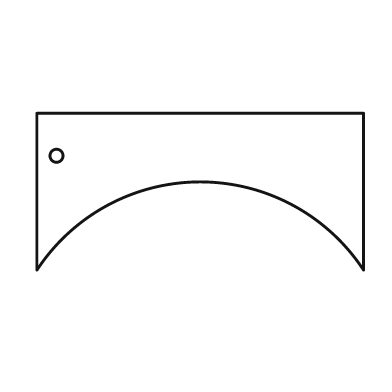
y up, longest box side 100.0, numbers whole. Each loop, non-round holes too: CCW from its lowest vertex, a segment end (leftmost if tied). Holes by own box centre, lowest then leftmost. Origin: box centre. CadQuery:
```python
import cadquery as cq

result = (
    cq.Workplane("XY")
    .moveTo(-50.0, -24.0)
    .threePointArc((0.0, 3.0), (50.0, -24.0))
    .lineTo(50.0, 24.0)
    .lineTo(-50.0, 24.0)
    .close()
    .moveTo(-44.0, 11.0)
    .circle(2.0)
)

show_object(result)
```